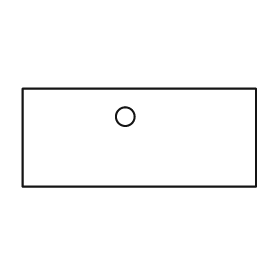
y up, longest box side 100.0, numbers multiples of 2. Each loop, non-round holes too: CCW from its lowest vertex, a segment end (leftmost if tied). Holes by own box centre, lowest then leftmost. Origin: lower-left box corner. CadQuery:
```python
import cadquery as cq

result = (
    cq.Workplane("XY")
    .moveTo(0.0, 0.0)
    .lineTo(100.0, 0.0)
    .lineTo(100.0, 42.0)
    .lineTo(0.0, 42.0)
    .close()
    .moveTo(44.0, 30.0)
    .circle(4.0)
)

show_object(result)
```